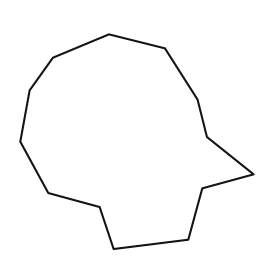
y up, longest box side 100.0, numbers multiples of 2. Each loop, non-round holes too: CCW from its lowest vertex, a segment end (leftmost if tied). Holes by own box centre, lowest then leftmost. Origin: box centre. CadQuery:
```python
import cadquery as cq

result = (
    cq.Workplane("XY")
    .moveTo(-10.0, -46.0)
    .lineTo(22.0, -42.0)
    .lineTo(28.0, -20.0)
    .lineTo(50.0, -14.0)
    .lineTo(30.0, 2.0)
    .lineTo(26.0, 18.0)
    .lineTo(12.0, 40.0)
    .lineTo(-12.0, 46.0)
    .lineTo(-36.0, 36.0)
    .lineTo(-46.0, 22.0)
    .lineTo(-50.0, 0.0)
    .lineTo(-38.0, -22.0)
    .lineTo(-16.0, -28.0)
    .close()
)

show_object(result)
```